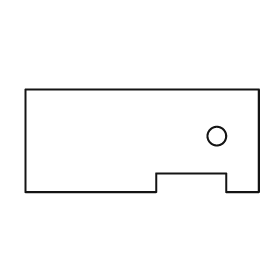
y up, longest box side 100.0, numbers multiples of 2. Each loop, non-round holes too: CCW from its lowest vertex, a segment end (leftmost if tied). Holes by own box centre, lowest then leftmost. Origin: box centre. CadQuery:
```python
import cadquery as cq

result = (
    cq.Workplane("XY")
    .moveTo(-50.0, -22.0)
    .lineTo(6.0, -22.0)
    .lineTo(6.0, -14.0)
    .lineTo(36.0, -14.0)
    .lineTo(36.0, -22.0)
    .lineTo(50.0, -22.0)
    .lineTo(50.0, 22.0)
    .lineTo(-50.0, 22.0)
    .close()
    .moveTo(32.0, 2.0)
    .circle(4.0)
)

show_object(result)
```